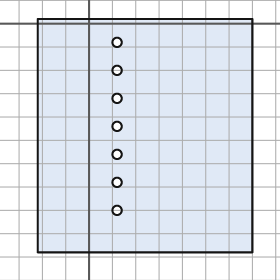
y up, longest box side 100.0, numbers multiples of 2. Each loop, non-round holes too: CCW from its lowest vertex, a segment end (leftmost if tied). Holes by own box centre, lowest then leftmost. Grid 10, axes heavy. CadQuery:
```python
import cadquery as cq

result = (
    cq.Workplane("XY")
    .moveTo(-22.0, -98.0)
    .lineTo(70.0, -98.0)
    .lineTo(70.0, 2.0)
    .lineTo(-22.0, 2.0)
    .close()
    .moveTo(12.0, -80.0)
    .circle(2.0)
    .moveTo(12.0, -68.0)
    .circle(2.0)
    .moveTo(12.0, -56.0)
    .circle(2.0)
    .moveTo(12.0, -44.0)
    .circle(2.0)
    .moveTo(12.0, -32.0)
    .circle(2.0)
    .moveTo(12.0, -20.0)
    .circle(2.0)
    .moveTo(12.0, -8.0)
    .circle(2.0)
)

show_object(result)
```